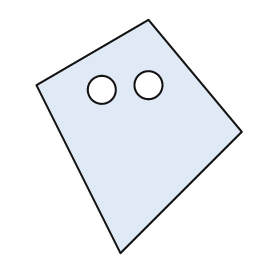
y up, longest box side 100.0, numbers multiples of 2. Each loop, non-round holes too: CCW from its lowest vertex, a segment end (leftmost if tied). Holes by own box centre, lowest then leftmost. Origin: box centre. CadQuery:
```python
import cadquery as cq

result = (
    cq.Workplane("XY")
    .moveTo(-8.0, -50.0)
    .lineTo(44.0, 2.0)
    .lineTo(4.0, 50.0)
    .lineTo(-44.0, 22.0)
    .close()
    .moveTo(-16.0, 20.0)
    .circle(6.0)
    .moveTo(4.0, 22.0)
    .circle(6.0)
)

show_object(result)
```